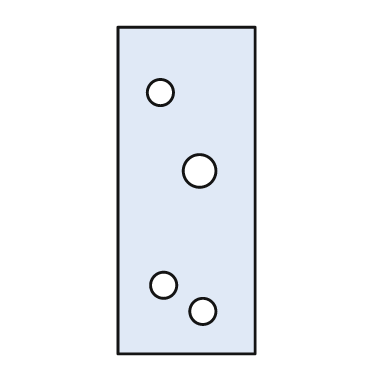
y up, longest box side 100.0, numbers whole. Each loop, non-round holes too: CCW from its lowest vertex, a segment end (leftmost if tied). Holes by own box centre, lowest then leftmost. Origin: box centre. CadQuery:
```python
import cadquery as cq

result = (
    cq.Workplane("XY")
    .moveTo(-21.0, -50.0)
    .lineTo(21.0, -50.0)
    .lineTo(21.0, 50.0)
    .lineTo(-21.0, 50.0)
    .close()
    .moveTo(5.0, -37.0)
    .circle(4.0)
    .moveTo(-7.0, -29.0)
    .circle(4.0)
    .moveTo(4.0, 6.0)
    .circle(5.0)
    .moveTo(-8.0, 30.0)
    .circle(4.0)
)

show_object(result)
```